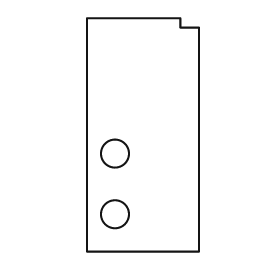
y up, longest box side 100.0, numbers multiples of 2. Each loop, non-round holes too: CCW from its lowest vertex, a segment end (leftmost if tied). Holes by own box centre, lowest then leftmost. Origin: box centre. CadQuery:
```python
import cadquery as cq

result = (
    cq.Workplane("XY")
    .moveTo(-24.0, -50.0)
    .lineTo(24.0, -50.0)
    .lineTo(24.0, 46.0)
    .lineTo(16.0, 46.0)
    .lineTo(16.0, 50.0)
    .lineTo(-24.0, 50.0)
    .close()
    .moveTo(-12.0, -34.0)
    .circle(6.0)
    .moveTo(-12.0, -8.0)
    .circle(6.0)
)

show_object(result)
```